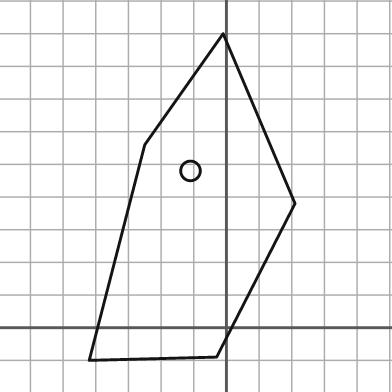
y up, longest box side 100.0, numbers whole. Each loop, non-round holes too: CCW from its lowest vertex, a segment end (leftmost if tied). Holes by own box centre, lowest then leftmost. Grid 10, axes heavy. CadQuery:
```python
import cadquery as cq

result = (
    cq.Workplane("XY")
    .moveTo(-42.0, -10.0)
    .lineTo(-3.0, -9.0)
    .lineTo(21.0, 38.0)
    .lineTo(-1.0, 90.0)
    .lineTo(-25.0, 56.0)
    .close()
    .moveTo(-11.0, 48.0)
    .circle(3.0)
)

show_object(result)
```